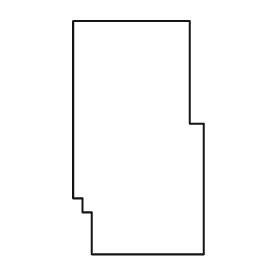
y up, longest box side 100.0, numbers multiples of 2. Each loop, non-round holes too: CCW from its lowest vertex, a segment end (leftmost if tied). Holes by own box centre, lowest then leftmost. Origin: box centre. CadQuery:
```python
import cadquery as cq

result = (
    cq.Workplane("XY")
    .moveTo(-20.0, -50.0)
    .lineTo(28.0, -50.0)
    .lineTo(28.0, 6.0)
    .lineTo(22.0, 6.0)
    .lineTo(22.0, 50.0)
    .lineTo(-28.0, 50.0)
    .lineTo(-28.0, -26.0)
    .lineTo(-24.0, -26.0)
    .lineTo(-24.0, -32.0)
    .lineTo(-20.0, -32.0)
    .close()
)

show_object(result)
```